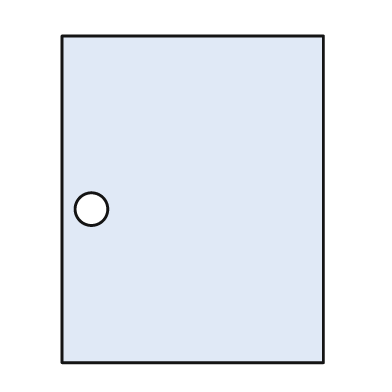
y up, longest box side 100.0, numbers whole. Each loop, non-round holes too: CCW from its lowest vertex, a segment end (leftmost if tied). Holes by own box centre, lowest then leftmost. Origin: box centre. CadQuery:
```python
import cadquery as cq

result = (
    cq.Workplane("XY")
    .moveTo(-40.0, -50.0)
    .lineTo(40.0, -50.0)
    .lineTo(40.0, 50.0)
    .lineTo(-40.0, 50.0)
    .close()
    .moveTo(-31.0, -3.0)
    .circle(5.0)
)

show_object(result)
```